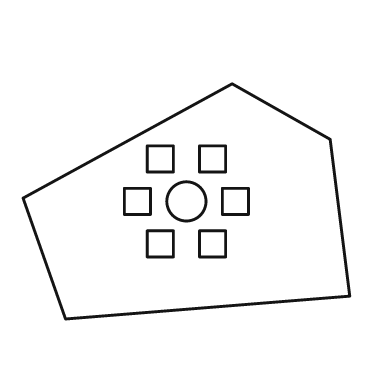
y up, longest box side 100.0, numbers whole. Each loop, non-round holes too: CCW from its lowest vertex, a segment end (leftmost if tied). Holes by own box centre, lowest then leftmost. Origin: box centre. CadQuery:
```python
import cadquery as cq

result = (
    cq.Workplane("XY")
    .moveTo(-37.0, -36.0)
    .lineTo(50.0, -29.0)
    .lineTo(44.0, 19.0)
    .lineTo(14.0, 36.0)
    .lineTo(-50.0, 1.0)
    .close()
    .moveTo(-12.0, -17.0)
    .lineTo(-4.0, -17.0)
    .lineTo(-4.0, -9.0)
    .lineTo(-12.0, -9.0)
    .close()
    .moveTo(4.0, -17.0)
    .lineTo(12.0, -17.0)
    .lineTo(12.0, -9.0)
    .lineTo(4.0, -9.0)
    .close()
    .moveTo(-19.0, -4.0)
    .lineTo(-11.0, -4.0)
    .lineTo(-11.0, 4.0)
    .lineTo(-19.0, 4.0)
    .close()
    .moveTo(0.0, 0.0)
    .circle(6.0)
    .moveTo(11.0, -4.0)
    .lineTo(19.0, -4.0)
    .lineTo(19.0, 4.0)
    .lineTo(11.0, 4.0)
    .close()
    .moveTo(-12.0, 9.0)
    .lineTo(-4.0, 9.0)
    .lineTo(-4.0, 17.0)
    .lineTo(-12.0, 17.0)
    .close()
    .moveTo(4.0, 9.0)
    .lineTo(12.0, 9.0)
    .lineTo(12.0, 17.0)
    .lineTo(4.0, 17.0)
    .close()
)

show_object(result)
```